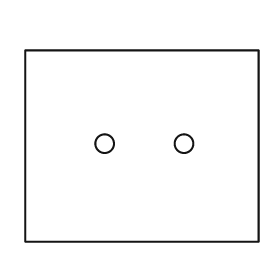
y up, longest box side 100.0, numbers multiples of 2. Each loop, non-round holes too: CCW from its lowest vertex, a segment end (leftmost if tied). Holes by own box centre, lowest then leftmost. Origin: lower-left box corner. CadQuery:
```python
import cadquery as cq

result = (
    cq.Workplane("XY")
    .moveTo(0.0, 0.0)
    .lineTo(100.0, 0.0)
    .lineTo(100.0, 82.0)
    .lineTo(0.0, 82.0)
    .close()
    .moveTo(34.0, 42.0)
    .circle(4.0)
    .moveTo(68.0, 42.0)
    .circle(4.0)
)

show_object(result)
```